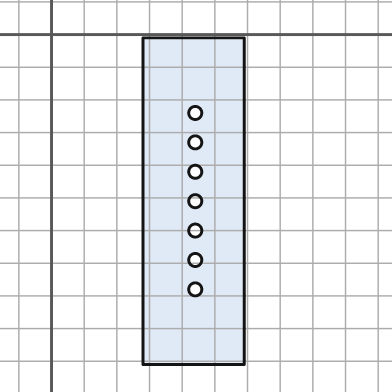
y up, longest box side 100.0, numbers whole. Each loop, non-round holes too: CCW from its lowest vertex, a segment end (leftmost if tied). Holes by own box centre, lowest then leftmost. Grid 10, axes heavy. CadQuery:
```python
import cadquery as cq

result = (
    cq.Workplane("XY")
    .moveTo(28.0, -101.0)
    .lineTo(59.0, -101.0)
    .lineTo(59.0, -1.0)
    .lineTo(28.0, -1.0)
    .close()
    .moveTo(44.0, -78.0)
    .circle(2.0)
    .moveTo(44.0, -69.0)
    .circle(2.0)
    .moveTo(44.0, -60.0)
    .circle(2.0)
    .moveTo(44.0, -51.0)
    .circle(2.0)
    .moveTo(44.0, -42.0)
    .circle(2.0)
    .moveTo(44.0, -33.0)
    .circle(2.0)
    .moveTo(44.0, -24.0)
    .circle(2.0)
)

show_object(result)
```